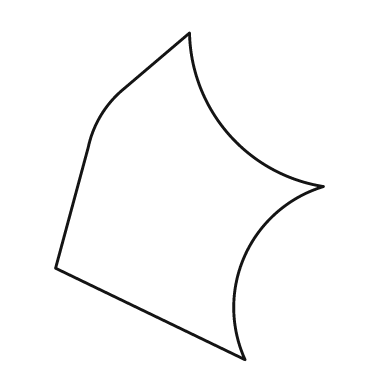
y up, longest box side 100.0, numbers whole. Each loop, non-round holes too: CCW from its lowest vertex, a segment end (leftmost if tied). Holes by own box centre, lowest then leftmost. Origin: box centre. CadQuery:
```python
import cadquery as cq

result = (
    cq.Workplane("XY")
    .moveTo(17.0, -50.0)
    .threePointArc((17.0, -18.0), (41.0, 3.0))
    .threePointArc((12.0, 19.0), (0.0, 50.0))
    .lineTo(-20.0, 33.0)
    .threePointArc((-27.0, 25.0), (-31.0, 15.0))
    .lineTo(-41.0, -22.0)
    .close()
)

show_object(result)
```